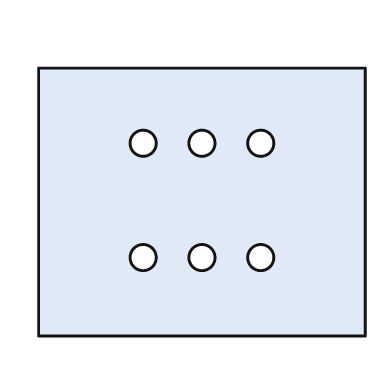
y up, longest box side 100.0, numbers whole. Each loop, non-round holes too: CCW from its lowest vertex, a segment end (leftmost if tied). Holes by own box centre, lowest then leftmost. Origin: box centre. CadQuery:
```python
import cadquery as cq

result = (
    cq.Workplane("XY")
    .moveTo(-50.0, -41.0)
    .lineTo(50.0, -41.0)
    .lineTo(50.0, 41.0)
    .lineTo(-50.0, 41.0)
    .close()
    .moveTo(-18.0, -17.0)
    .circle(4.0)
    .moveTo(0.0, -17.0)
    .circle(4.0)
    .moveTo(18.0, -17.0)
    .circle(4.0)
    .moveTo(-18.0, 18.0)
    .circle(4.0)
    .moveTo(0.0, 18.0)
    .circle(4.0)
    .moveTo(18.0, 18.0)
    .circle(4.0)
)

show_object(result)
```